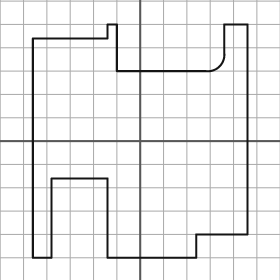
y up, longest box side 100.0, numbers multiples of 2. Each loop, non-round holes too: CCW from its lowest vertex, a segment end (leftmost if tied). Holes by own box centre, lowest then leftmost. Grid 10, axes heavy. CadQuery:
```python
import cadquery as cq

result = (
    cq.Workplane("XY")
    .moveTo(-46.0, -50.0)
    .lineTo(-38.0, -50.0)
    .lineTo(-38.0, -16.0)
    .lineTo(-14.0, -16.0)
    .lineTo(-14.0, -50.0)
    .lineTo(24.0, -50.0)
    .lineTo(24.0, -40.0)
    .lineTo(46.0, -40.0)
    .lineTo(46.0, 50.0)
    .lineTo(36.0, 50.0)
    .lineTo(36.0, 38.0)
    .threePointArc((34.0, 32.0), (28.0, 30.0))
    .lineTo(-10.0, 30.0)
    .lineTo(-10.0, 50.0)
    .lineTo(-14.0, 50.0)
    .lineTo(-14.0, 44.0)
    .lineTo(-46.0, 44.0)
    .close()
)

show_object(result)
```